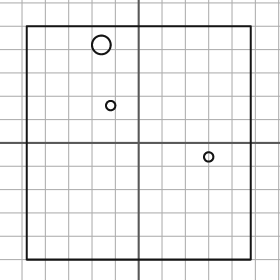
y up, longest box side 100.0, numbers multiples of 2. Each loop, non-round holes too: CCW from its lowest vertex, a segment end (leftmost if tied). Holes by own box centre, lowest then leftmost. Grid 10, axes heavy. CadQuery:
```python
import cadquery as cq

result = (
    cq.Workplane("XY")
    .moveTo(-48.0, -50.0)
    .lineTo(48.0, -50.0)
    .lineTo(48.0, 50.0)
    .lineTo(-48.0, 50.0)
    .close()
    .moveTo(30.0, -6.0)
    .circle(2.0)
    .moveTo(-12.0, 16.0)
    .circle(2.0)
    .moveTo(-16.0, 42.0)
    .circle(4.0)
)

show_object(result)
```